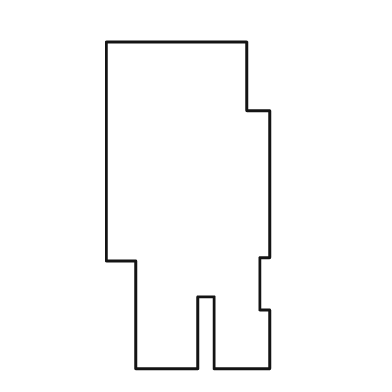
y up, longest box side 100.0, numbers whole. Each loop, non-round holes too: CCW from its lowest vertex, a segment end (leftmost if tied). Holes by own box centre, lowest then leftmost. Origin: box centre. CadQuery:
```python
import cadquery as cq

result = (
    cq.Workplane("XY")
    .moveTo(-16.0, -50.0)
    .lineTo(3.0, -50.0)
    .lineTo(3.0, -28.0)
    .lineTo(8.0, -28.0)
    .lineTo(8.0, -50.0)
    .lineTo(25.0, -50.0)
    .lineTo(25.0, -32.0)
    .lineTo(22.0, -32.0)
    .lineTo(22.0, -16.0)
    .lineTo(25.0, -16.0)
    .lineTo(25.0, 29.0)
    .lineTo(18.0, 29.0)
    .lineTo(18.0, 50.0)
    .lineTo(-25.0, 50.0)
    .lineTo(-25.0, -17.0)
    .lineTo(-16.0, -17.0)
    .close()
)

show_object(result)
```